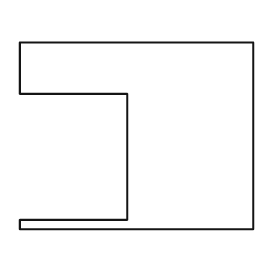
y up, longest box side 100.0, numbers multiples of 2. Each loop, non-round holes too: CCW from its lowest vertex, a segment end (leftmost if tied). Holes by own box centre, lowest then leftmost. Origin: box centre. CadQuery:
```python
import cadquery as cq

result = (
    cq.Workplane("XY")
    .moveTo(-50.0, -40.0)
    .lineTo(50.0, -40.0)
    .lineTo(50.0, 40.0)
    .lineTo(-50.0, 40.0)
    .lineTo(-50.0, 18.0)
    .lineTo(-4.0, 18.0)
    .lineTo(-4.0, -36.0)
    .lineTo(-50.0, -36.0)
    .close()
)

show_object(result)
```